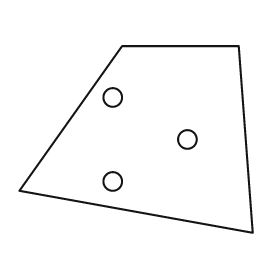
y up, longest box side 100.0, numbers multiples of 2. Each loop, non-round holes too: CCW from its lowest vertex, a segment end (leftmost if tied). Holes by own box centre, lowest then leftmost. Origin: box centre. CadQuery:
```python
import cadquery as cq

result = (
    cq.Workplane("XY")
    .moveTo(50.0, -40.0)
    .lineTo(44.0, 40.0)
    .lineTo(-6.0, 40.0)
    .lineTo(-50.0, -22.0)
    .close()
    .moveTo(-10.0, -18.0)
    .circle(4.0)
    .moveTo(22.0, 0.0)
    .circle(4.0)
    .moveTo(-10.0, 18.0)
    .circle(4.0)
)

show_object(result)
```